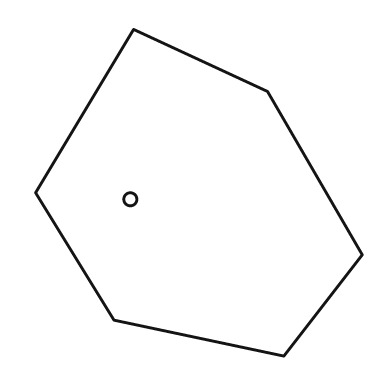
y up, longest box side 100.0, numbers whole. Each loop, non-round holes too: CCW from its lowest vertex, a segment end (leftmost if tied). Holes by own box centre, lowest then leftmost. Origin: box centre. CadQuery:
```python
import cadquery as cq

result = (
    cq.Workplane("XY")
    .moveTo(26.0, -50.0)
    .lineTo(50.0, -19.0)
    .lineTo(21.0, 31.0)
    .lineTo(-20.0, 50.0)
    .lineTo(-50.0, 0.0)
    .lineTo(-26.0, -39.0)
    .close()
    .moveTo(-21.0, -2.0)
    .circle(2.0)
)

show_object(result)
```